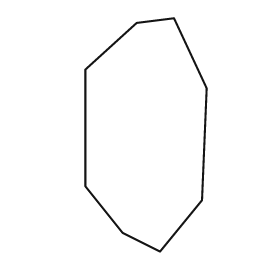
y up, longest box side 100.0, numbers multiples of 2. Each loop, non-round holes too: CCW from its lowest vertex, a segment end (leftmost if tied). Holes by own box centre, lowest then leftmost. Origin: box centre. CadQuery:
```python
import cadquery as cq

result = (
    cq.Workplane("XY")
    .moveTo(6.0, -50.0)
    .lineTo(24.0, -28.0)
    .lineTo(26.0, 20.0)
    .lineTo(12.0, 50.0)
    .lineTo(-4.0, 48.0)
    .lineTo(-26.0, 28.0)
    .lineTo(-26.0, -22.0)
    .lineTo(-10.0, -42.0)
    .close()
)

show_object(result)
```